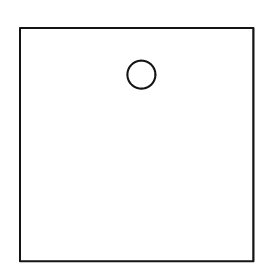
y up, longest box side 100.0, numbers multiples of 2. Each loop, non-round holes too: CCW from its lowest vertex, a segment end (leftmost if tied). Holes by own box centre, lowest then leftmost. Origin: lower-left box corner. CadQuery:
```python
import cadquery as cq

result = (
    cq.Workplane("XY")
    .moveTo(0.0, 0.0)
    .lineTo(100.0, 0.0)
    .lineTo(100.0, 100.0)
    .lineTo(0.0, 100.0)
    .close()
    .moveTo(52.0, 80.0)
    .circle(6.0)
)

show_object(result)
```